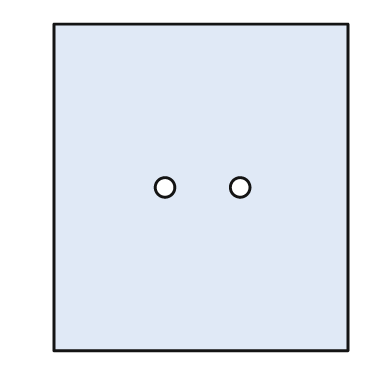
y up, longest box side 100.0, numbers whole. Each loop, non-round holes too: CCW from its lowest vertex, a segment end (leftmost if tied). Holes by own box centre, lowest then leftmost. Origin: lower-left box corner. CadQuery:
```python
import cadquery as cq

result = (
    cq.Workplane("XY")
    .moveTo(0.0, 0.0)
    .lineTo(90.0, 0.0)
    .lineTo(90.0, 100.0)
    .lineTo(0.0, 100.0)
    .close()
    .moveTo(34.0, 50.0)
    .circle(3.0)
    .moveTo(57.0, 50.0)
    .circle(3.0)
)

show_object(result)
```